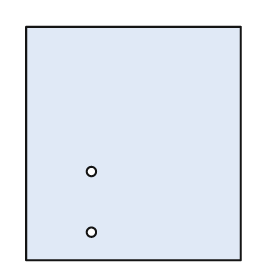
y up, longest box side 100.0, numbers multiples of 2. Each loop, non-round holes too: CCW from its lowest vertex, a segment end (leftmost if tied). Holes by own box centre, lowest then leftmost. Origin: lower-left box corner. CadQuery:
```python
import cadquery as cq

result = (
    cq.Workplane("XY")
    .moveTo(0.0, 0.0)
    .lineTo(92.0, 0.0)
    .lineTo(92.0, 100.0)
    .lineTo(0.0, 100.0)
    .close()
    .moveTo(28.0, 12.0)
    .circle(2.0)
    .moveTo(28.0, 38.0)
    .circle(2.0)
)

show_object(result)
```